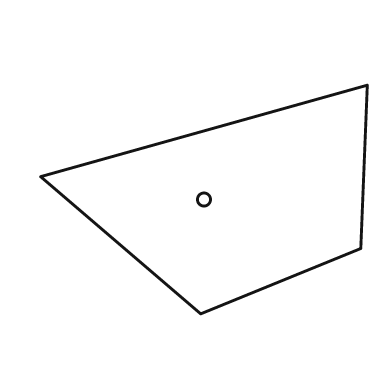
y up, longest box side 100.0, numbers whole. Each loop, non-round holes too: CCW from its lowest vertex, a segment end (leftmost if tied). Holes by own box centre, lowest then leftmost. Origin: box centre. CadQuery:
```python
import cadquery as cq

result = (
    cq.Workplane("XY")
    .moveTo(-1.0, -35.0)
    .lineTo(48.0, -15.0)
    .lineTo(50.0, 35.0)
    .lineTo(-50.0, 7.0)
    .close()
    .moveTo(0.0, 0.0)
    .circle(2.0)
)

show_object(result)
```